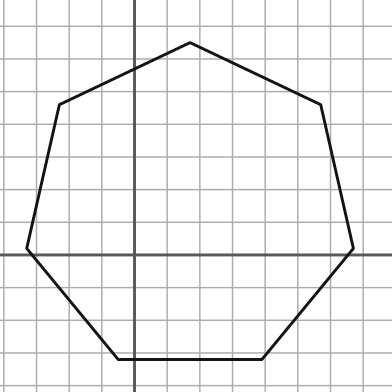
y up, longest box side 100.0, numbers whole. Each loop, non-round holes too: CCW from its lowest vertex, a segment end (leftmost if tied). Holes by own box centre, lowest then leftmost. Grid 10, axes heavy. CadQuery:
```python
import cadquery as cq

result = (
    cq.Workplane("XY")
    .moveTo(-5.0, -32.0)
    .lineTo(39.0, -32.0)
    .lineTo(67.0, 2.0)
    .lineTo(57.0, 46.0)
    .lineTo(17.0, 65.0)
    .lineTo(-23.0, 46.0)
    .lineTo(-33.0, 2.0)
    .close()
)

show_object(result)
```